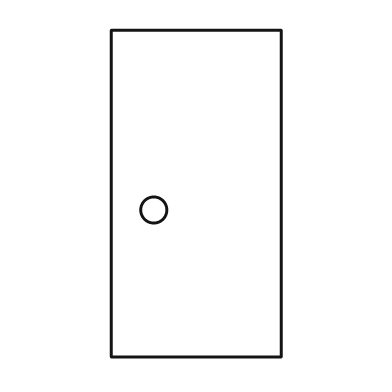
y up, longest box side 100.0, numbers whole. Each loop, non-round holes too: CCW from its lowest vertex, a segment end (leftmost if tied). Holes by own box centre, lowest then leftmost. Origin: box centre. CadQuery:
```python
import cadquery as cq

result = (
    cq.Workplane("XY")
    .moveTo(-26.0, -50.0)
    .lineTo(26.0, -50.0)
    .lineTo(26.0, 50.0)
    .lineTo(-26.0, 50.0)
    .close()
    .moveTo(-13.0, -5.0)
    .circle(4.0)
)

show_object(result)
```